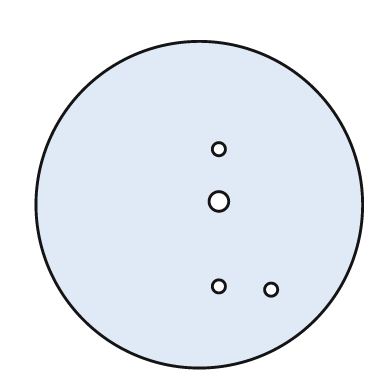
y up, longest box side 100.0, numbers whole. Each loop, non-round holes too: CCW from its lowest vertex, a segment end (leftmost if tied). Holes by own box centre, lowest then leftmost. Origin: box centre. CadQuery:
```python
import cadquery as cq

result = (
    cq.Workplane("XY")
    .moveTo(0.0, 0.0)
    .circle(50.0)
    .moveTo(22.0, -26.0)
    .circle(2.0)
    .moveTo(6.0, -25.0)
    .circle(2.0)
    .moveTo(6.0, 1.0)
    .circle(3.0)
    .moveTo(6.0, 17.0)
    .circle(2.0)
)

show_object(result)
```